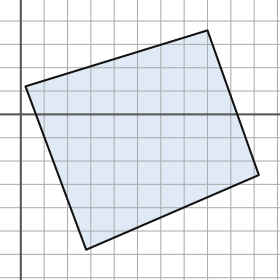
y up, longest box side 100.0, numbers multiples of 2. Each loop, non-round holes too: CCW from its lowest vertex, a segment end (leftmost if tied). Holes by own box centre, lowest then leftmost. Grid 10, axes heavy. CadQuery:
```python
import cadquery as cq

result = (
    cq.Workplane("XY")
    .moveTo(28.0, -58.0)
    .lineTo(102.0, -26.0)
    .lineTo(80.0, 36.0)
    .lineTo(2.0, 12.0)
    .close()
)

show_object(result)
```